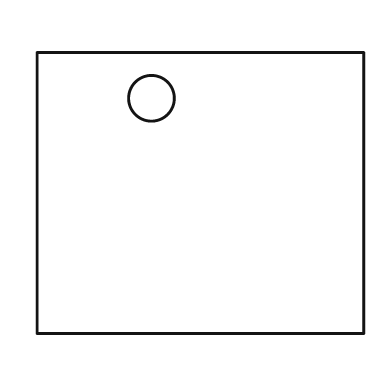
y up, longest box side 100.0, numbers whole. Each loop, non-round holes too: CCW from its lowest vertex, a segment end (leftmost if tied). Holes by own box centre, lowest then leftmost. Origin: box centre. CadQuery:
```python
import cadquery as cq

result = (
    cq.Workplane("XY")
    .moveTo(-50.0, -43.0)
    .lineTo(50.0, -43.0)
    .lineTo(50.0, 43.0)
    .lineTo(-50.0, 43.0)
    .close()
    .moveTo(-15.0, 29.0)
    .circle(7.0)
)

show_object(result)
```